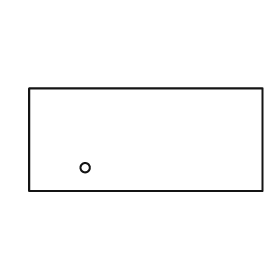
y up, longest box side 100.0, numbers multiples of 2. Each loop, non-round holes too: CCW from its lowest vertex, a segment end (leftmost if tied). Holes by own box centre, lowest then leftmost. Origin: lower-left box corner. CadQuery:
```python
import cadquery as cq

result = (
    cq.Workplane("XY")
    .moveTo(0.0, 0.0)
    .lineTo(100.0, 0.0)
    .lineTo(100.0, 44.0)
    .lineTo(0.0, 44.0)
    .close()
    .moveTo(24.0, 10.0)
    .circle(2.0)
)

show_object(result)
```